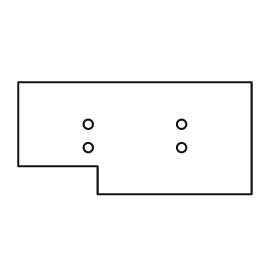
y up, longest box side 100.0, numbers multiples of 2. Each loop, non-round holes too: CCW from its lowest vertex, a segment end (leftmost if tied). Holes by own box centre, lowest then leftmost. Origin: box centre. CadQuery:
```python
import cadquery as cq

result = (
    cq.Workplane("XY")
    .moveTo(-16.0, -24.0)
    .lineTo(50.0, -24.0)
    .lineTo(50.0, 24.0)
    .lineTo(-50.0, 24.0)
    .lineTo(-50.0, -12.0)
    .lineTo(-16.0, -12.0)
    .close()
    .moveTo(-20.0, -4.0)
    .circle(2.0)
    .moveTo(20.0, -4.0)
    .circle(2.0)
    .moveTo(-20.0, 6.0)
    .circle(2.0)
    .moveTo(20.0, 6.0)
    .circle(2.0)
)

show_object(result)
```